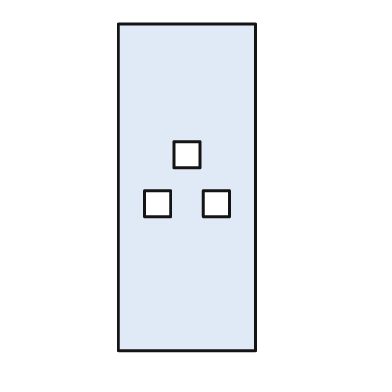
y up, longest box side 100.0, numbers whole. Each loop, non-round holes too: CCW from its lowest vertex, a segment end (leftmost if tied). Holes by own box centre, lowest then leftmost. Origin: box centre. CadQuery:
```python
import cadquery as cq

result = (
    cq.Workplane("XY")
    .moveTo(-21.0, -50.0)
    .lineTo(21.0, -50.0)
    .lineTo(21.0, 50.0)
    .lineTo(-21.0, 50.0)
    .close()
    .moveTo(-13.0, -9.0)
    .lineTo(-5.0, -9.0)
    .lineTo(-5.0, -1.0)
    .lineTo(-13.0, -1.0)
    .close()
    .moveTo(5.0, -9.0)
    .lineTo(13.0, -9.0)
    .lineTo(13.0, -1.0)
    .lineTo(5.0, -1.0)
    .close()
    .moveTo(-4.0, 6.0)
    .lineTo(4.0, 6.0)
    .lineTo(4.0, 14.0)
    .lineTo(-4.0, 14.0)
    .close()
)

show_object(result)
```